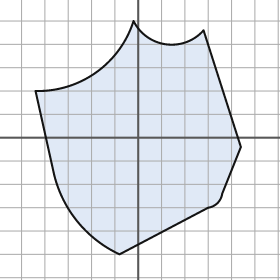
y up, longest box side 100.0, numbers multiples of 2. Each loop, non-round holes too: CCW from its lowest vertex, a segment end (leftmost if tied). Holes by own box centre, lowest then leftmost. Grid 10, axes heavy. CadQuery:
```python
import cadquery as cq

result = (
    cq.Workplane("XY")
    .moveTo(-8.0, -50.0)
    .lineTo(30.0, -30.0)
    .threePointArc((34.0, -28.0), (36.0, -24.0))
    .lineTo(44.0, -4.0)
    .lineTo(28.0, 46.0)
    .threePointArc((12.0, 40.0), (-2.0, 50.0))
    .threePointArc((-18.0, 28.0), (-44.0, 20.0))
    .lineTo(-36.0, -16.0)
    .threePointArc((-26.0, -36.0), (-8.0, -50.0))
    .close()
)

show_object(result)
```